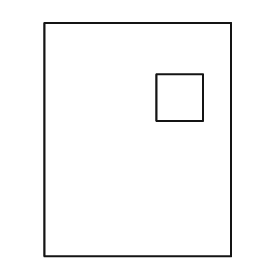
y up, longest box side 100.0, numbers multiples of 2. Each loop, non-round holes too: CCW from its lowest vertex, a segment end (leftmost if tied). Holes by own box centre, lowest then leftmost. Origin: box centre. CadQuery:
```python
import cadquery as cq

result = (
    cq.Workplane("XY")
    .moveTo(-40.0, -50.0)
    .lineTo(40.0, -50.0)
    .lineTo(40.0, 50.0)
    .lineTo(-40.0, 50.0)
    .close()
    .moveTo(8.0, 8.0)
    .lineTo(28.0, 8.0)
    .lineTo(28.0, 28.0)
    .lineTo(8.0, 28.0)
    .close()
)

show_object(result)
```